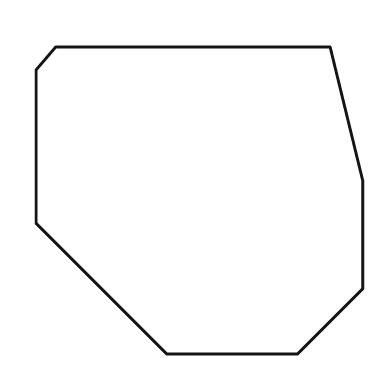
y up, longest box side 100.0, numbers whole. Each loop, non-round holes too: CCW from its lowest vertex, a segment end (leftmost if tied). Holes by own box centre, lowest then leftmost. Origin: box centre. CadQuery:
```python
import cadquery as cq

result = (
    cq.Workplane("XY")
    .moveTo(-10.0, -47.0)
    .lineTo(30.0, -47.0)
    .lineTo(50.0, -27.0)
    .lineTo(50.0, 6.0)
    .lineTo(40.0, 47.0)
    .lineTo(-44.0, 47.0)
    .lineTo(-50.0, 40.0)
    .lineTo(-50.0, -7.0)
    .close()
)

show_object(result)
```